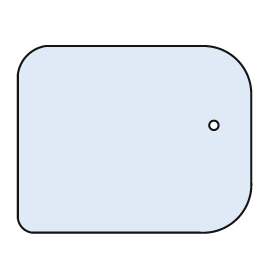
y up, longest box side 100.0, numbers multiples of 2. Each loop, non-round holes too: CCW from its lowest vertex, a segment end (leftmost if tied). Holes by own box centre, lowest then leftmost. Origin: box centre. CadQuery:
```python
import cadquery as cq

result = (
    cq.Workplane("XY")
    .moveTo(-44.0, -40.0)
    .lineTo(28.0, -40.0)
    .threePointArc((44.0, -34.0), (50.0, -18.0))
    .lineTo(50.0, 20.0)
    .threePointArc((44.0, 34.0), (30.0, 40.0))
    .lineTo(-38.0, 40.0)
    .threePointArc((-46.0, 36.0), (-50.0, 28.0))
    .lineTo(-50.0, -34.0)
    .threePointArc((-48.0, -38.0), (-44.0, -40.0))
    .close()
    .moveTo(34.0, 6.0)
    .circle(2.0)
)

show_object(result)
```